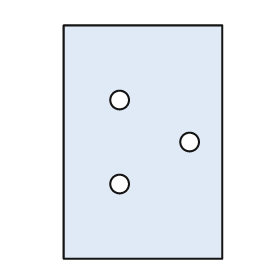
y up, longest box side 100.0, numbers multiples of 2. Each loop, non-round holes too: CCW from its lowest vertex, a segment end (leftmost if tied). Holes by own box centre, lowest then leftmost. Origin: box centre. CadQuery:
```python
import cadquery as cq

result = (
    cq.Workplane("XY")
    .moveTo(-34.0, -50.0)
    .lineTo(34.0, -50.0)
    .lineTo(34.0, 50.0)
    .lineTo(-34.0, 50.0)
    .close()
    .moveTo(-10.0, -18.0)
    .circle(4.0)
    .moveTo(20.0, 0.0)
    .circle(4.0)
    .moveTo(-10.0, 18.0)
    .circle(4.0)
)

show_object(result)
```